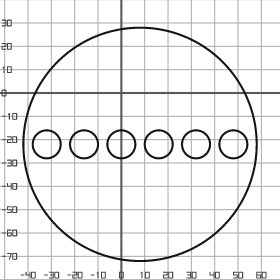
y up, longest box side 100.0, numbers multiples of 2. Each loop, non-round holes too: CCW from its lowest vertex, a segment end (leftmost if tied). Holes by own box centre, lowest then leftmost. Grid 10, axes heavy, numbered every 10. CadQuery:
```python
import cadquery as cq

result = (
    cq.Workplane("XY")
    .moveTo(8.0, -22.0)
    .circle(50.0)
    .moveTo(-32.0, -22.0)
    .circle(6.0)
    .moveTo(-16.0, -22.0)
    .circle(6.0)
    .moveTo(0.0, -22.0)
    .circle(6.0)
    .moveTo(16.0, -22.0)
    .circle(6.0)
    .moveTo(32.0, -22.0)
    .circle(6.0)
    .moveTo(48.0, -22.0)
    .circle(6.0)
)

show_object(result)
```